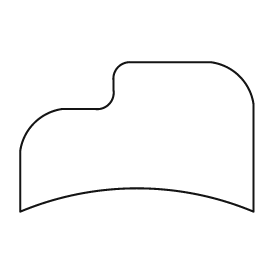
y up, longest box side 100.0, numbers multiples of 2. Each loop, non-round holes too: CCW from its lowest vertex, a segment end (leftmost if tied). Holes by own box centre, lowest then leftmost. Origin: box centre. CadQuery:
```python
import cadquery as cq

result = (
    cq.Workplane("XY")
    .moveTo(-50.0, -32.0)
    .threePointArc((0.0, -22.0), (50.0, -32.0))
    .lineTo(50.0, 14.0)
    .threePointArc((44.0, 26.0), (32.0, 32.0))
    .lineTo(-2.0, 32.0)
    .threePointArc((-8.0, 30.0), (-10.0, 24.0))
    .lineTo(-10.0, 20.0)
    .threePointArc((-12.0, 14.0), (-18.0, 12.0))
    .lineTo(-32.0, 12.0)
    .threePointArc((-44.0, 6.0), (-50.0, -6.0))
    .close()
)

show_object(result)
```